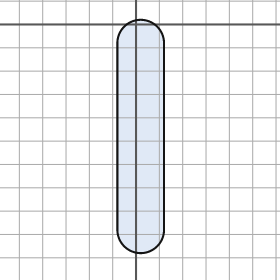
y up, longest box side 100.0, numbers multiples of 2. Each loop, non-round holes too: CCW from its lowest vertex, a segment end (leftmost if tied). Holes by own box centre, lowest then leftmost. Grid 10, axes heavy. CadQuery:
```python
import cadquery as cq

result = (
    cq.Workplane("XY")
    .moveTo(-8.0, -88.0)
    .threePointArc((2.0, -98.0), (12.0, -88.0))
    .lineTo(12.0, -8.0)
    .threePointArc((2.0, 2.0), (-8.0, -8.0))
    .close()
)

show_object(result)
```